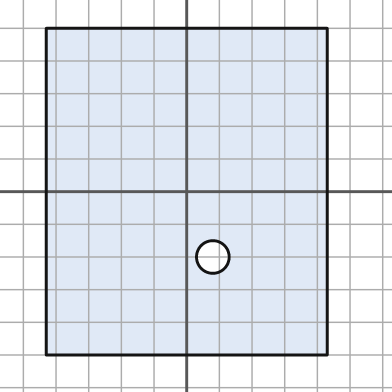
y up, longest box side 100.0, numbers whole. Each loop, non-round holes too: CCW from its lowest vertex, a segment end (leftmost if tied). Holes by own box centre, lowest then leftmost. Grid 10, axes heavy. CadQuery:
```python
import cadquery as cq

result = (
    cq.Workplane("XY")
    .moveTo(-43.0, -50.0)
    .lineTo(43.0, -50.0)
    .lineTo(43.0, 50.0)
    .lineTo(-43.0, 50.0)
    .close()
    .moveTo(8.0, -20.0)
    .circle(5.0)
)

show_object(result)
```